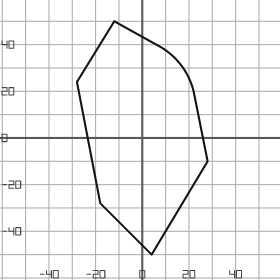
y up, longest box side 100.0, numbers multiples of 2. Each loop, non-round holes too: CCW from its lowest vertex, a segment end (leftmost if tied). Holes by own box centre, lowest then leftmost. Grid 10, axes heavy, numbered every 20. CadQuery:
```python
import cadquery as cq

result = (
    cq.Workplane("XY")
    .moveTo(4.0, -50.0)
    .lineTo(28.0, -10.0)
    .lineTo(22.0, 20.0)
    .threePointArc((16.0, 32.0), (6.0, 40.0))
    .lineTo(-12.0, 50.0)
    .lineTo(-28.0, 24.0)
    .lineTo(-18.0, -28.0)
    .close()
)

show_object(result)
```